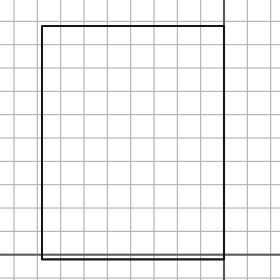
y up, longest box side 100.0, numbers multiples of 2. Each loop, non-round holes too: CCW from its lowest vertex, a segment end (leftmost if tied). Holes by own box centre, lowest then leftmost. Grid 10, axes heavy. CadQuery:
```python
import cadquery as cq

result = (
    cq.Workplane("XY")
    .moveTo(-78.0, -2.0)
    .lineTo(0.0, -2.0)
    .lineTo(0.0, 98.0)
    .lineTo(-78.0, 98.0)
    .close()
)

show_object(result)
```